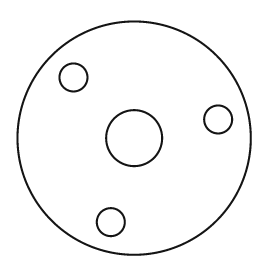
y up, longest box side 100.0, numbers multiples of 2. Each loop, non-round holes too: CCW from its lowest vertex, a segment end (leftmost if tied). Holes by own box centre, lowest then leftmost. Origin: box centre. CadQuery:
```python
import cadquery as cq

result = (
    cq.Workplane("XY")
    .moveTo(0.0, 0.0)
    .circle(50.0)
    .moveTo(-10.0, -36.0)
    .circle(6.0)
    .moveTo(0.0, 0.0)
    .circle(12.0)
    .moveTo(36.0, 8.0)
    .circle(6.0)
    .moveTo(-26.0, 26.0)
    .circle(6.0)
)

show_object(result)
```